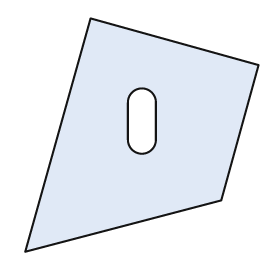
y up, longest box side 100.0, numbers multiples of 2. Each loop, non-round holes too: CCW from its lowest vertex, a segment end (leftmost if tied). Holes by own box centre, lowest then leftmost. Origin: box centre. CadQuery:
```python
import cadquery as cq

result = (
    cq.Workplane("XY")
    .moveTo(-50.0, -50.0)
    .lineTo(34.0, -28.0)
    .lineTo(50.0, 30.0)
    .lineTo(-22.0, 50.0)
    .close()
    .moveTo(-6.0, -2.0)
    .threePointArc((0.0, -8.0), (6.0, -2.0))
    .lineTo(6.0, 14.0)
    .threePointArc((0.0, 20.0), (-6.0, 14.0))
    .close()
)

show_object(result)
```